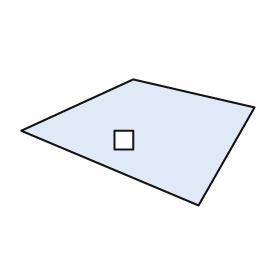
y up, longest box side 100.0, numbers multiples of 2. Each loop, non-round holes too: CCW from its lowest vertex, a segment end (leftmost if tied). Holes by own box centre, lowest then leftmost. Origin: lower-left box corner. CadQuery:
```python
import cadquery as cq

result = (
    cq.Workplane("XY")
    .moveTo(76.0, 0.0)
    .lineTo(100.0, 42.0)
    .lineTo(48.0, 54.0)
    .lineTo(0.0, 32.0)
    .close()
    .moveTo(40.0, 24.0)
    .lineTo(48.0, 24.0)
    .lineTo(48.0, 32.0)
    .lineTo(40.0, 32.0)
    .close()
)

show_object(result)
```